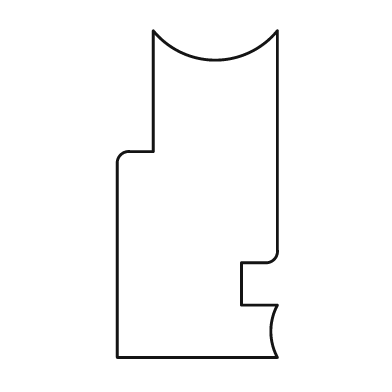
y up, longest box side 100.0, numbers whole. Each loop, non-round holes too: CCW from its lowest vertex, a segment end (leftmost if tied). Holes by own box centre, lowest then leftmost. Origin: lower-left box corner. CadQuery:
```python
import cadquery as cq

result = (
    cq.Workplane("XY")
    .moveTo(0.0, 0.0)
    .lineTo(49.0, 0.0)
    .threePointArc((47.0, 8.0), (49.0, 16.0))
    .lineTo(38.0, 16.0)
    .lineTo(38.0, 29.0)
    .lineTo(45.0, 29.0)
    .threePointArc((48.0, 30.0), (49.0, 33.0))
    .lineTo(49.0, 100.0)
    .threePointArc((30.0, 91.0), (11.0, 100.0))
    .lineTo(11.0, 63.0)
    .lineTo(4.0, 63.0)
    .threePointArc((1.0, 62.0), (0.0, 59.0))
    .close()
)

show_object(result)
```